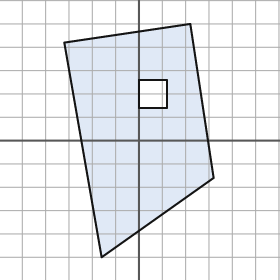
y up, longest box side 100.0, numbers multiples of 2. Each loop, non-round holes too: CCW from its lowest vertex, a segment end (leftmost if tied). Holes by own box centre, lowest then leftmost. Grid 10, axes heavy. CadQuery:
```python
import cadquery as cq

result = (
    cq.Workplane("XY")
    .moveTo(-16.0, -50.0)
    .lineTo(32.0, -16.0)
    .lineTo(22.0, 50.0)
    .lineTo(-32.0, 42.0)
    .close()
    .moveTo(0.0, 14.0)
    .lineTo(12.0, 14.0)
    .lineTo(12.0, 26.0)
    .lineTo(0.0, 26.0)
    .close()
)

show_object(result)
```